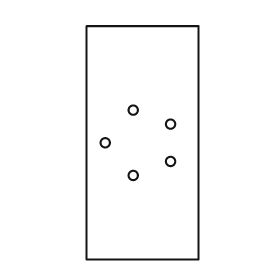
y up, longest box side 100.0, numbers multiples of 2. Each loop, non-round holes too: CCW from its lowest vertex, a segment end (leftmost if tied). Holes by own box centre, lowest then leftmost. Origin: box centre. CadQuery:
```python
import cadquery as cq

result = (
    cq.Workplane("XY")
    .moveTo(-24.0, -50.0)
    .lineTo(24.0, -50.0)
    .lineTo(24.0, 50.0)
    .lineTo(-24.0, 50.0)
    .close()
    .moveTo(-4.0, -14.0)
    .circle(2.0)
    .moveTo(12.0, -8.0)
    .circle(2.0)
    .moveTo(-16.0, 0.0)
    .circle(2.0)
    .moveTo(12.0, 8.0)
    .circle(2.0)
    .moveTo(-4.0, 14.0)
    .circle(2.0)
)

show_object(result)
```